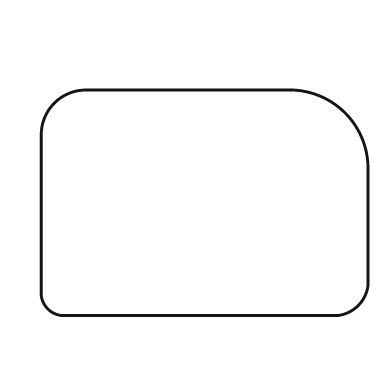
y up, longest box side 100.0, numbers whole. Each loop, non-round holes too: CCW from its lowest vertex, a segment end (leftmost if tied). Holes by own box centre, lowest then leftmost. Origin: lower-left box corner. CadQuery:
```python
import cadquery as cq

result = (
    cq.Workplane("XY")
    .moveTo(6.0, 0.0)
    .lineTo(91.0, 0.0)
    .threePointArc((97.0, 3.0), (100.0, 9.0))
    .lineTo(100.0, 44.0)
    .threePointArc((93.0, 62.0), (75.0, 69.0))
    .lineTo(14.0, 69.0)
    .threePointArc((4.0, 65.0), (0.0, 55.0))
    .lineTo(0.0, 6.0)
    .threePointArc((2.0, 2.0), (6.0, 0.0))
    .close()
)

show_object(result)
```